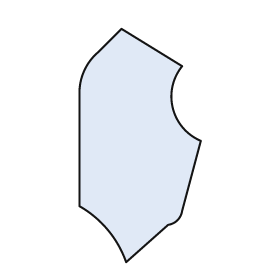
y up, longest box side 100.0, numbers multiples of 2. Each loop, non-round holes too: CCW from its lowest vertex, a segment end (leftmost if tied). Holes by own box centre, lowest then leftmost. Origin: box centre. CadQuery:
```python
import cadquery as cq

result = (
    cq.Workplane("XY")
    .moveTo(-6.0, -50.0)
    .lineTo(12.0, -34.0)
    .threePointArc((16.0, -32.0), (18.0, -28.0))
    .lineTo(26.0, 2.0)
    .threePointArc((14.0, 16.0), (18.0, 34.0))
    .lineTo(-8.0, 50.0)
    .lineTo(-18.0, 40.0)
    .threePointArc((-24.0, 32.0), (-26.0, 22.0))
    .lineTo(-26.0, -26.0)
    .threePointArc((-14.0, -36.0), (-6.0, -50.0))
    .close()
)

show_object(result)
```